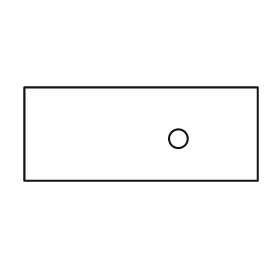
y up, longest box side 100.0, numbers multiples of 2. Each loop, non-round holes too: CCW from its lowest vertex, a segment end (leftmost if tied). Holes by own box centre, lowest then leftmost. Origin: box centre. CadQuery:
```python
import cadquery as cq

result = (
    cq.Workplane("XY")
    .moveTo(-50.0, -20.0)
    .lineTo(50.0, -20.0)
    .lineTo(50.0, 20.0)
    .lineTo(-50.0, 20.0)
    .close()
    .moveTo(16.0, -2.0)
    .circle(4.0)
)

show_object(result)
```